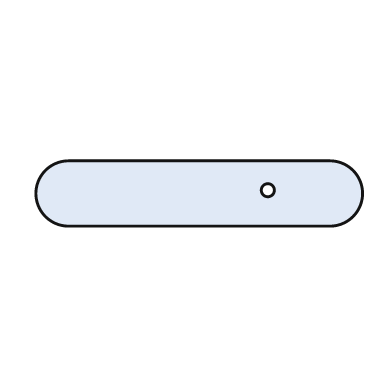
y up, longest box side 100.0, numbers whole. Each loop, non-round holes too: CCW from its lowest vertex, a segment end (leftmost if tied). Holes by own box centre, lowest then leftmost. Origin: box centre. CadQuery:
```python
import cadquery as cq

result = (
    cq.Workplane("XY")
    .moveTo(-40.0, -10.0)
    .lineTo(40.0, -10.0)
    .threePointArc((50.0, 0.0), (40.0, 10.0))
    .lineTo(-40.0, 10.0)
    .threePointArc((-50.0, 0.0), (-40.0, -10.0))
    .close()
    .moveTo(21.0, 1.0)
    .circle(2.0)
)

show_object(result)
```